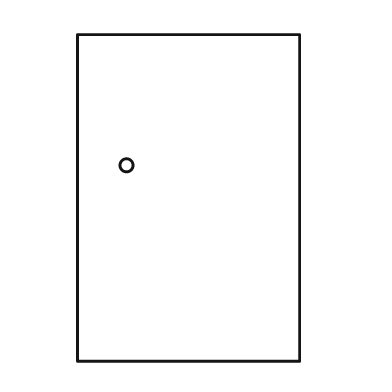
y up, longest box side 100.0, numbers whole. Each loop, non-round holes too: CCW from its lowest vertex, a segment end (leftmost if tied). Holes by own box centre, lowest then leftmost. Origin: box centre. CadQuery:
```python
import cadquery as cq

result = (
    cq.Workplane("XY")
    .moveTo(-34.0, -50.0)
    .lineTo(34.0, -50.0)
    .lineTo(34.0, 50.0)
    .lineTo(-34.0, 50.0)
    .close()
    .moveTo(-19.0, 10.0)
    .circle(2.0)
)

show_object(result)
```